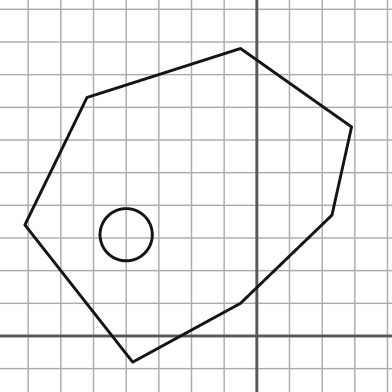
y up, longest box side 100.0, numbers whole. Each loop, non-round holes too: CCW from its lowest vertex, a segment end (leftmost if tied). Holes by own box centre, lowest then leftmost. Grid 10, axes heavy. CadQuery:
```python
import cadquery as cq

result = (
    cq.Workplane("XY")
    .moveTo(-38.0, -8.0)
    .lineTo(-5.0, 10.0)
    .lineTo(23.0, 37.0)
    .lineTo(29.0, 64.0)
    .lineTo(-5.0, 88.0)
    .lineTo(-52.0, 73.0)
    .lineTo(-71.0, 34.0)
    .close()
    .moveTo(-40.0, 31.0)
    .circle(8.0)
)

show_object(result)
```